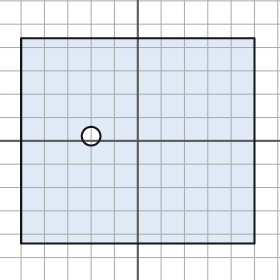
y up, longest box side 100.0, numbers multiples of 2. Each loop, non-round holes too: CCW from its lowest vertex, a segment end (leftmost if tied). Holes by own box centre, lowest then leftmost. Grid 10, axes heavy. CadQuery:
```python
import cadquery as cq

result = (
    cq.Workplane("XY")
    .moveTo(-50.0, -44.0)
    .lineTo(50.0, -44.0)
    .lineTo(50.0, 44.0)
    .lineTo(-50.0, 44.0)
    .close()
    .moveTo(-20.0, 2.0)
    .circle(4.0)
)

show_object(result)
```